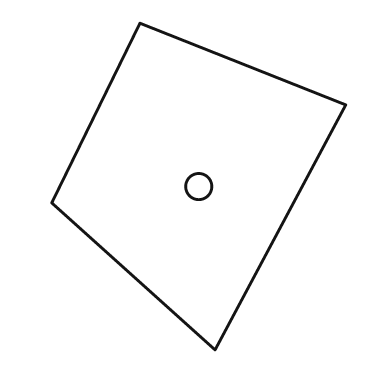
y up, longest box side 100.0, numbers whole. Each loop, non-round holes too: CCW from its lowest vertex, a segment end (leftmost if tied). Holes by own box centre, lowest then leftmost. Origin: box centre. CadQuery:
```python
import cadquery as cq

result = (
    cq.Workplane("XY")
    .moveTo(5.0, -50.0)
    .lineTo(45.0, 25.0)
    .lineTo(-18.0, 50.0)
    .lineTo(-45.0, -5.0)
    .close()
    .moveTo(0.0, 0.0)
    .circle(4.0)
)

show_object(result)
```